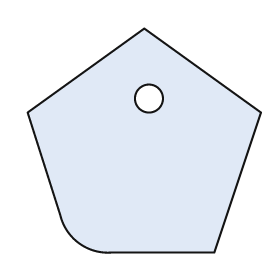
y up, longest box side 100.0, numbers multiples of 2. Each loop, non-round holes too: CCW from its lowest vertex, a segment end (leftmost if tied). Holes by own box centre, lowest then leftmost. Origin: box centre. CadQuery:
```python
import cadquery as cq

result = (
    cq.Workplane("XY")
    .moveTo(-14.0, -48.0)
    .lineTo(30.0, -48.0)
    .lineTo(50.0, 12.0)
    .lineTo(0.0, 48.0)
    .lineTo(-50.0, 12.0)
    .lineTo(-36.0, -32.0)
    .threePointArc((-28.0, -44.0), (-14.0, -48.0))
    .close()
    .moveTo(2.0, 18.0)
    .circle(6.0)
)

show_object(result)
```